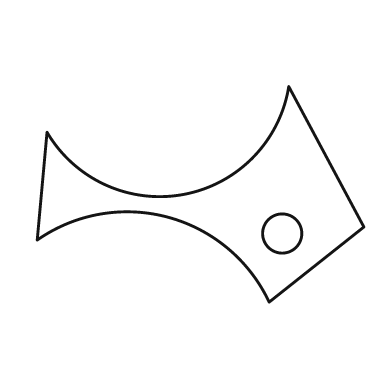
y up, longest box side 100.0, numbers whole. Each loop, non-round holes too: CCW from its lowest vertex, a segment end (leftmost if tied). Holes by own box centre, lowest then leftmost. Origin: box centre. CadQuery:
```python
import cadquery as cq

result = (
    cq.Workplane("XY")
    .moveTo(21.0, -33.0)
    .lineTo(50.0, -10.0)
    .lineTo(27.0, 33.0)
    .threePointArc((-5.0, 0.0), (-47.0, 19.0))
    .lineTo(-50.0, -14.0)
    .threePointArc((-10.0, -7.0), (21.0, -33.0))
    .close()
    .moveTo(25.0, -12.0)
    .circle(6.0)
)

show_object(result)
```